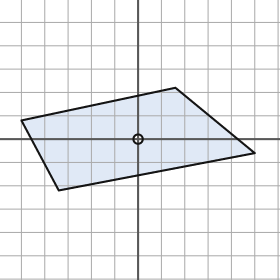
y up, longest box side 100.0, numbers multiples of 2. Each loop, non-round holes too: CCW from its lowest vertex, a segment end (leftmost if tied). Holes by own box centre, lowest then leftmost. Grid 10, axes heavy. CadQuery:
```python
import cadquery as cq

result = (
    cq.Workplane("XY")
    .moveTo(-34.0, -22.0)
    .lineTo(50.0, -6.0)
    .lineTo(16.0, 22.0)
    .lineTo(-50.0, 8.0)
    .close()
    .moveTo(0.0, 0.0)
    .circle(2.0)
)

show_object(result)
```